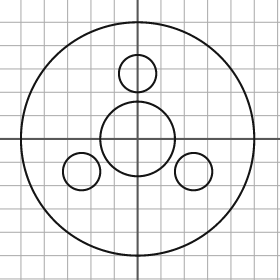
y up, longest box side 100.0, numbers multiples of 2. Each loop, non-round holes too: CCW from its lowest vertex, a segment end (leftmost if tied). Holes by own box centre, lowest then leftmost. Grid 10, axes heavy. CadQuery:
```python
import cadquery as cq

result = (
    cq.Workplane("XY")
    .moveTo(0.0, 0.0)
    .circle(50.0)
    .moveTo(-24.0, -14.0)
    .circle(8.0)
    .moveTo(24.0, -14.0)
    .circle(8.0)
    .moveTo(0.0, 0.0)
    .circle(16.0)
    .moveTo(0.0, 28.0)
    .circle(8.0)
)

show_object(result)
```